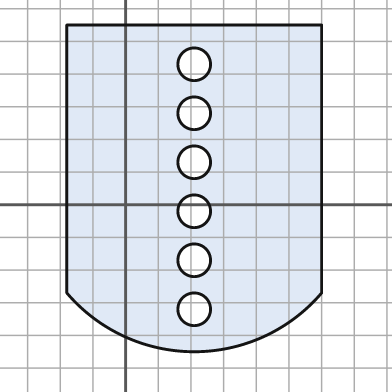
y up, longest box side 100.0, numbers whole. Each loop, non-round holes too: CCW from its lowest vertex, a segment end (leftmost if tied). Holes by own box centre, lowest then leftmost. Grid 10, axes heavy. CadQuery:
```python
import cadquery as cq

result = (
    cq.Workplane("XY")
    .moveTo(-18.0, -27.0)
    .threePointArc((21.0, -45.0), (60.0, -27.0))
    .lineTo(60.0, 55.0)
    .lineTo(-18.0, 55.0)
    .close()
    .moveTo(21.0, -32.0)
    .circle(5.0)
    .moveTo(21.0, -17.0)
    .circle(5.0)
    .moveTo(21.0, -2.0)
    .circle(5.0)
    .moveTo(21.0, 13.0)
    .circle(5.0)
    .moveTo(21.0, 28.0)
    .circle(5.0)
    .moveTo(21.0, 43.0)
    .circle(5.0)
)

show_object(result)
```